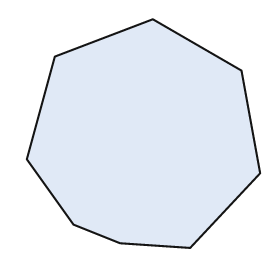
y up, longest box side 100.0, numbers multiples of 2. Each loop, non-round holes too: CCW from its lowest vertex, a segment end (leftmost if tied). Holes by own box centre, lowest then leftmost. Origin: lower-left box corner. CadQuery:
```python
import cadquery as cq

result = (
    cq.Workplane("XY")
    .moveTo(70.0, 0.0)
    .lineTo(100.0, 32.0)
    .lineTo(92.0, 76.0)
    .lineTo(54.0, 98.0)
    .lineTo(12.0, 82.0)
    .lineTo(0.0, 38.0)
    .lineTo(20.0, 10.0)
    .lineTo(40.0, 2.0)
    .close()
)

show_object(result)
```